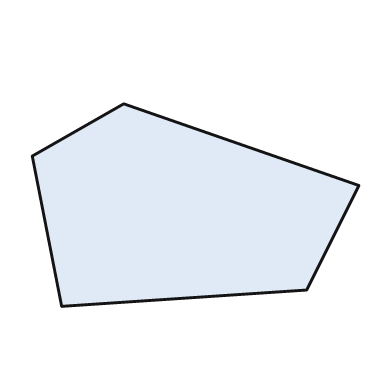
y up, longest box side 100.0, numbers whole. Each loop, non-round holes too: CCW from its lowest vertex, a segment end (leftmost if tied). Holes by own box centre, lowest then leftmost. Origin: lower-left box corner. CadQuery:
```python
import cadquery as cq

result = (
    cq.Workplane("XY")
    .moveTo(9.0, 0.0)
    .lineTo(84.0, 5.0)
    .lineTo(100.0, 37.0)
    .lineTo(28.0, 62.0)
    .lineTo(0.0, 46.0)
    .close()
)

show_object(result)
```